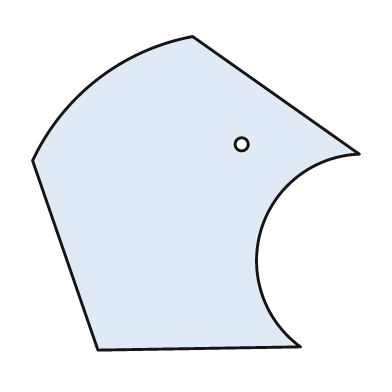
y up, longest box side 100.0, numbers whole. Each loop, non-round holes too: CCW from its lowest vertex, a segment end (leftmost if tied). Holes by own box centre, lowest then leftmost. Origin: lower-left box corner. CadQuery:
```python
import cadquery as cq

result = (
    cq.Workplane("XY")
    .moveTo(20.0, 0.0)
    .lineTo(82.0, 1.0)
    .threePointArc((70.0, 37.0), (100.0, 60.0))
    .lineTo(49.0, 96.0)
    .threePointArc((20.0, 83.0), (0.0, 58.0))
    .close()
    .moveTo(64.0, 63.0)
    .circle(2.0)
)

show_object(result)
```